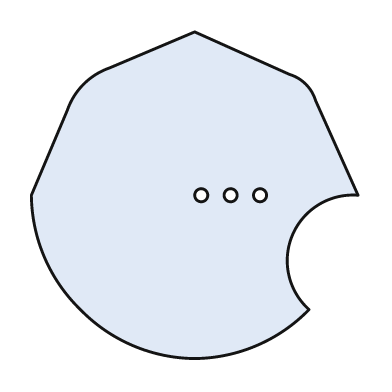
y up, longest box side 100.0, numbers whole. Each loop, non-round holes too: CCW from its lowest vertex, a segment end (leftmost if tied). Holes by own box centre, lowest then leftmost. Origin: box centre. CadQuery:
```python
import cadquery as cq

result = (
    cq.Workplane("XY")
    .moveTo(0.0, -50.0)
    .threePointArc((19.0, -46.0), (35.0, -35.0))
    .threePointArc((30.0, -12.0), (50.0, 0.0))
    .lineTo(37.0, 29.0)
    .threePointArc((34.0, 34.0), (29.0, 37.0))
    .lineTo(0.0, 50.0)
    .lineTo(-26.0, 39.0)
    .threePointArc((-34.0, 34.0), (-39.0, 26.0))
    .lineTo(-50.0, 0.0)
    .threePointArc((-46.0, -19.0), (-35.0, -35.0))
    .threePointArc((-19.0, -46.0), (0.0, -50.0))
    .close()
    .moveTo(2.0, 0.0)
    .circle(2.0)
    .moveTo(11.0, 0.0)
    .circle(2.0)
    .moveTo(20.0, 0.0)
    .circle(2.0)
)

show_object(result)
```